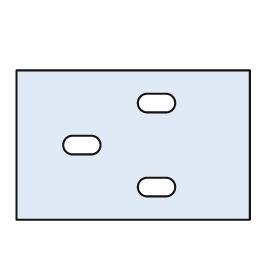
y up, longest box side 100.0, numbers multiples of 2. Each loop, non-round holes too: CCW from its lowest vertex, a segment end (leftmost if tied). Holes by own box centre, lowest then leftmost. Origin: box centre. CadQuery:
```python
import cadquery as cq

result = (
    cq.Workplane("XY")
    .moveTo(-50.0, -32.0)
    .lineTo(50.0, -32.0)
    .lineTo(50.0, 32.0)
    .lineTo(-50.0, 32.0)
    .close()
    .moveTo(6.0, -22.0)
    .lineTo(14.0, -22.0)
    .threePointArc((18.0, -18.0), (14.0, -14.0))
    .lineTo(6.0, -14.0)
    .threePointArc((2.0, -18.0), (6.0, -22.0))
    .close()
    .moveTo(-26.0, -4.0)
    .lineTo(-18.0, -4.0)
    .threePointArc((-14.0, 0.0), (-18.0, 4.0))
    .lineTo(-26.0, 4.0)
    .threePointArc((-30.0, 0.0), (-26.0, -4.0))
    .close()
    .moveTo(6.0, 14.0)
    .lineTo(14.0, 14.0)
    .threePointArc((18.0, 18.0), (14.0, 22.0))
    .lineTo(6.0, 22.0)
    .threePointArc((2.0, 18.0), (6.0, 14.0))
    .close()
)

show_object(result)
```